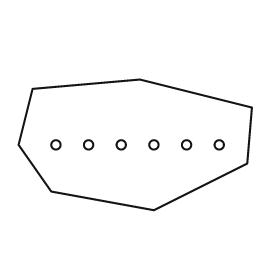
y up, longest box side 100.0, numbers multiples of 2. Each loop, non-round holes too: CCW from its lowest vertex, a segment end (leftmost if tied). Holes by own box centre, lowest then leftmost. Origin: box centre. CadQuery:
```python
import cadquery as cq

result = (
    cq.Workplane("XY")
    .moveTo(8.0, -28.0)
    .lineTo(48.0, -8.0)
    .lineTo(50.0, 16.0)
    .lineTo(2.0, 28.0)
    .lineTo(-44.0, 24.0)
    .lineTo(-50.0, 0.0)
    .lineTo(-36.0, -20.0)
    .close()
    .moveTo(-34.0, 0.0)
    .circle(2.0)
    .moveTo(-20.0, 0.0)
    .circle(2.0)
    .moveTo(-6.0, 0.0)
    .circle(2.0)
    .moveTo(8.0, 0.0)
    .circle(2.0)
    .moveTo(22.0, 0.0)
    .circle(2.0)
    .moveTo(36.0, 0.0)
    .circle(2.0)
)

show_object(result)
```